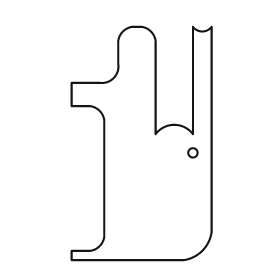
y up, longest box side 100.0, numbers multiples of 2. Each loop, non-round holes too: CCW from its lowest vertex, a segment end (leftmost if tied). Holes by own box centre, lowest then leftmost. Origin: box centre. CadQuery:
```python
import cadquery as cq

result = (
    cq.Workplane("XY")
    .moveTo(-30.0, -50.0)
    .lineTo(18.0, -50.0)
    .threePointArc((26.0, -46.0), (30.0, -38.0))
    .lineTo(30.0, 50.0)
    .threePointArc((26.0, 48.0), (22.0, 50.0))
    .lineTo(22.0, 4.0)
    .threePointArc((14.0, 8.0), (6.0, 4.0))
    .lineTo(6.0, 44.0)
    .threePointArc((4.0, 48.0), (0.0, 50.0))
    .lineTo(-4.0, 50.0)
    .threePointArc((-8.0, 48.0), (-10.0, 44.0))
    .lineTo(-10.0, 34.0)
    .threePointArc((-12.0, 28.0), (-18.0, 26.0))
    .lineTo(-30.0, 26.0)
    .lineTo(-30.0, 16.0)
    .lineTo(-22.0, 16.0)
    .threePointArc((-18.0, 14.0), (-16.0, 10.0))
    .lineTo(-16.0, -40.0)
    .threePointArc((-18.0, -44.0), (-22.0, -46.0))
    .lineTo(-30.0, -46.0)
    .close()
    .moveTo(22.0, -4.0)
    .circle(2.0)
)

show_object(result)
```